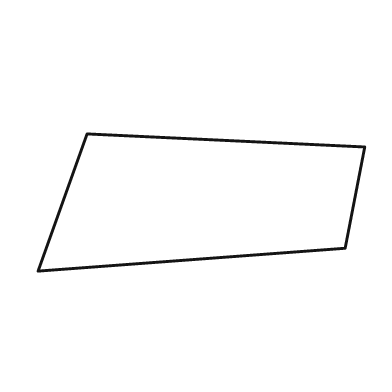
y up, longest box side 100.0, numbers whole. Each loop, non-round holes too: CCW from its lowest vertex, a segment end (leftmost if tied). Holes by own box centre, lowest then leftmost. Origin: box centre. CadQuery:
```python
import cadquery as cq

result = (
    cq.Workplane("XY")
    .moveTo(-50.0, -21.0)
    .lineTo(44.0, -14.0)
    .lineTo(50.0, 17.0)
    .lineTo(-35.0, 21.0)
    .close()
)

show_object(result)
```